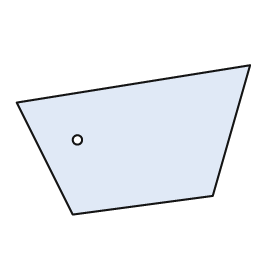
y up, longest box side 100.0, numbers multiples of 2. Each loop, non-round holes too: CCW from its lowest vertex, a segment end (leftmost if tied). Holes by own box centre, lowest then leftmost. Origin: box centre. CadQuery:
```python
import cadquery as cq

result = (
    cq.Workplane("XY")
    .moveTo(-26.0, -32.0)
    .lineTo(34.0, -24.0)
    .lineTo(50.0, 32.0)
    .lineTo(-50.0, 16.0)
    .close()
    .moveTo(-24.0, 0.0)
    .circle(2.0)
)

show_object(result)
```